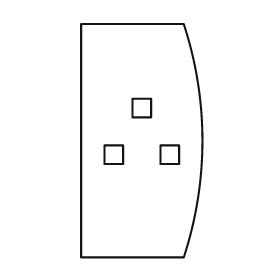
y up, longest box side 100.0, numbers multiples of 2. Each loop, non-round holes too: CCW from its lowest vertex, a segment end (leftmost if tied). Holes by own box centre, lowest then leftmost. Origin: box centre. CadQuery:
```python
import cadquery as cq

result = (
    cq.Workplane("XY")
    .moveTo(-26.0, -50.0)
    .lineTo(18.0, -50.0)
    .threePointArc((26.0, 0.0), (18.0, 50.0))
    .lineTo(-26.0, 50.0)
    .close()
    .moveTo(-16.0, -10.0)
    .lineTo(-8.0, -10.0)
    .lineTo(-8.0, -2.0)
    .lineTo(-16.0, -2.0)
    .close()
    .moveTo(8.0, -10.0)
    .lineTo(16.0, -10.0)
    .lineTo(16.0, -2.0)
    .lineTo(8.0, -2.0)
    .close()
    .moveTo(-4.0, 10.0)
    .lineTo(4.0, 10.0)
    .lineTo(4.0, 18.0)
    .lineTo(-4.0, 18.0)
    .close()
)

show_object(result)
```